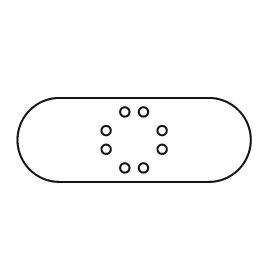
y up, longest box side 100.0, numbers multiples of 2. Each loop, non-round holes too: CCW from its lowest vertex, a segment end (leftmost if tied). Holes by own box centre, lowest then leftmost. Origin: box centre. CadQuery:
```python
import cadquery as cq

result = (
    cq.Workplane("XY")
    .moveTo(-32.0, -18.0)
    .lineTo(32.0, -18.0)
    .threePointArc((50.0, 0.0), (32.0, 18.0))
    .lineTo(-32.0, 18.0)
    .threePointArc((-50.0, 0.0), (-32.0, -18.0))
    .close()
    .moveTo(-4.0, -12.0)
    .circle(2.0)
    .moveTo(4.0, -12.0)
    .circle(2.0)
    .moveTo(-12.0, -4.0)
    .circle(2.0)
    .moveTo(12.0, -4.0)
    .circle(2.0)
    .moveTo(-12.0, 4.0)
    .circle(2.0)
    .moveTo(12.0, 4.0)
    .circle(2.0)
    .moveTo(-4.0, 12.0)
    .circle(2.0)
    .moveTo(4.0, 12.0)
    .circle(2.0)
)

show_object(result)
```